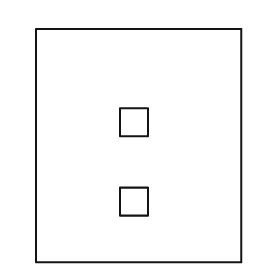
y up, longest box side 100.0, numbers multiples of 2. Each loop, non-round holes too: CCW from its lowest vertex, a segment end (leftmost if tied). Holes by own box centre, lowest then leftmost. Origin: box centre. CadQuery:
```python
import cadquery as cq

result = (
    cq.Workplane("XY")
    .moveTo(-44.0, -50.0)
    .lineTo(44.0, -50.0)
    .lineTo(44.0, 50.0)
    .lineTo(-44.0, 50.0)
    .close()
    .moveTo(-8.0, -30.0)
    .lineTo(4.0, -30.0)
    .lineTo(4.0, -18.0)
    .lineTo(-8.0, -18.0)
    .close()
    .moveTo(-8.0, 4.0)
    .lineTo(4.0, 4.0)
    .lineTo(4.0, 16.0)
    .lineTo(-8.0, 16.0)
    .close()
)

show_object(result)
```